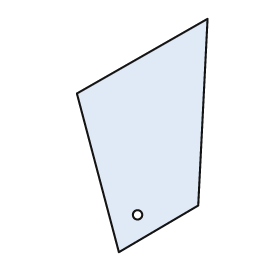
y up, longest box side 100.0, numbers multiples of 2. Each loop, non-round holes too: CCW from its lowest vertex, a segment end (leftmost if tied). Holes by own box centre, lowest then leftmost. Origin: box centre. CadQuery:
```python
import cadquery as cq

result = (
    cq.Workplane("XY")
    .moveTo(-10.0, -50.0)
    .lineTo(24.0, -30.0)
    .lineTo(28.0, 50.0)
    .lineTo(-28.0, 18.0)
    .close()
    .moveTo(-2.0, -34.0)
    .circle(2.0)
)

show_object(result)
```